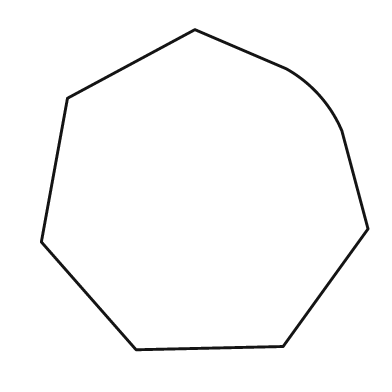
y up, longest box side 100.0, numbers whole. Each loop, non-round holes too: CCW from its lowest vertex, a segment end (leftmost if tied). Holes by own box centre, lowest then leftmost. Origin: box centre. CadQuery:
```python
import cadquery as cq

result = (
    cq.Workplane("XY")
    .moveTo(-21.0, -49.0)
    .lineTo(24.0, -48.0)
    .lineTo(50.0, -12.0)
    .lineTo(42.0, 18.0)
    .threePointArc((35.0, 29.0), (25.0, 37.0))
    .lineTo(-3.0, 49.0)
    .lineTo(-42.0, 28.0)
    .lineTo(-50.0, -16.0)
    .close()
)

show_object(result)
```